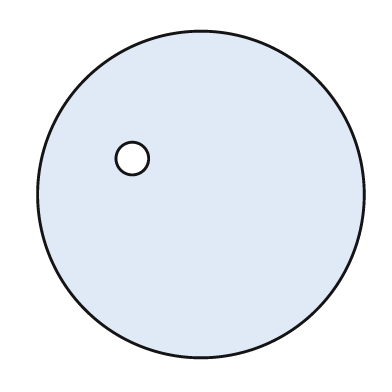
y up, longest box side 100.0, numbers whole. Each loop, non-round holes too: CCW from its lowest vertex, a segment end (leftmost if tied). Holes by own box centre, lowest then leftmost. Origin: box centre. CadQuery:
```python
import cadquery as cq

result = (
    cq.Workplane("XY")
    .moveTo(0.0, 0.0)
    .circle(50.0)
    .moveTo(-21.0, 11.0)
    .circle(5.0)
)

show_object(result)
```